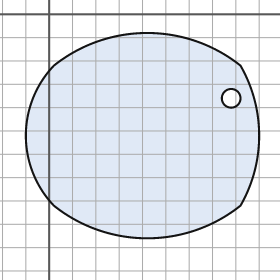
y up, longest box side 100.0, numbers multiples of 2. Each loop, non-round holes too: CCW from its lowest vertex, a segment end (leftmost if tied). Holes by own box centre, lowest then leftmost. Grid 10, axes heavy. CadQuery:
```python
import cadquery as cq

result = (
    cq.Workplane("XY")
    .moveTo(2.0, -82.0)
    .threePointArc((42.0, -96.0), (82.0, -82.0))
    .threePointArc((90.0, -52.0), (82.0, -22.0))
    .threePointArc((42.0, -8.0), (2.0, -22.0))
    .threePointArc((-10.0, -52.0), (2.0, -82.0))
    .close()
    .moveTo(78.0, -36.0)
    .circle(4.0)
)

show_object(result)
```